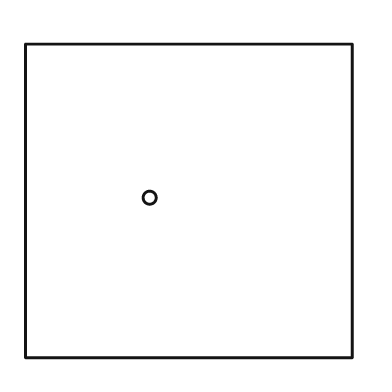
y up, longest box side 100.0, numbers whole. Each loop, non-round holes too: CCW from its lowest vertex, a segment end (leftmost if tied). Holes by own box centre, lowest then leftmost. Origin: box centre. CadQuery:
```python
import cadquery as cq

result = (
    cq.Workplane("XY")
    .moveTo(-50.0, -48.0)
    .lineTo(50.0, -48.0)
    .lineTo(50.0, 48.0)
    .lineTo(-50.0, 48.0)
    .close()
    .moveTo(-12.0, 1.0)
    .circle(2.0)
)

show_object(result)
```